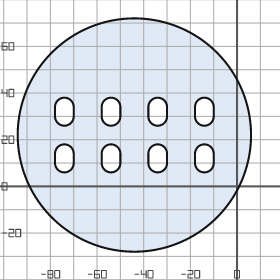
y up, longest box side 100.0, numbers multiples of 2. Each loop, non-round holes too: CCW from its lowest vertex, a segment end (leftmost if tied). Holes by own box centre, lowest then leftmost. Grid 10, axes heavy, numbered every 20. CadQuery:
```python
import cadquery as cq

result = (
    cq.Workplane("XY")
    .moveTo(-44.0, 22.0)
    .circle(50.0)
    .moveTo(-78.0, 10.0)
    .threePointArc((-74.0, 6.0), (-70.0, 10.0))
    .lineTo(-70.0, 14.0)
    .threePointArc((-74.0, 18.0), (-78.0, 14.0))
    .close()
    .moveTo(-58.0, 10.0)
    .threePointArc((-54.0, 6.0), (-50.0, 10.0))
    .lineTo(-50.0, 14.0)
    .threePointArc((-54.0, 18.0), (-58.0, 14.0))
    .close()
    .moveTo(-38.0, 10.0)
    .threePointArc((-34.0, 6.0), (-30.0, 10.0))
    .lineTo(-30.0, 14.0)
    .threePointArc((-34.0, 18.0), (-38.0, 14.0))
    .close()
    .moveTo(-18.0, 10.0)
    .threePointArc((-14.0, 6.0), (-10.0, 10.0))
    .lineTo(-10.0, 14.0)
    .threePointArc((-14.0, 18.0), (-18.0, 14.0))
    .close()
    .moveTo(-78.0, 30.0)
    .threePointArc((-74.0, 26.0), (-70.0, 30.0))
    .lineTo(-70.0, 34.0)
    .threePointArc((-74.0, 38.0), (-78.0, 34.0))
    .close()
    .moveTo(-58.0, 30.0)
    .threePointArc((-54.0, 26.0), (-50.0, 30.0))
    .lineTo(-50.0, 34.0)
    .threePointArc((-54.0, 38.0), (-58.0, 34.0))
    .close()
    .moveTo(-38.0, 30.0)
    .threePointArc((-34.0, 26.0), (-30.0, 30.0))
    .lineTo(-30.0, 34.0)
    .threePointArc((-34.0, 38.0), (-38.0, 34.0))
    .close()
    .moveTo(-18.0, 30.0)
    .threePointArc((-14.0, 26.0), (-10.0, 30.0))
    .lineTo(-10.0, 34.0)
    .threePointArc((-14.0, 38.0), (-18.0, 34.0))
    .close()
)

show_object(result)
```